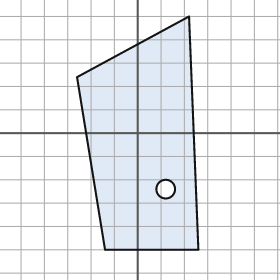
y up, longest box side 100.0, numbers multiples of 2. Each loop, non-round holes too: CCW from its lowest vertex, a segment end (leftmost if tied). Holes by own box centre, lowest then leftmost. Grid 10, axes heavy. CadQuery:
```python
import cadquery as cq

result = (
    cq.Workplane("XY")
    .moveTo(-14.0, -50.0)
    .lineTo(26.0, -50.0)
    .lineTo(22.0, 50.0)
    .lineTo(-26.0, 24.0)
    .close()
    .moveTo(12.0, -24.0)
    .circle(4.0)
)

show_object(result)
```